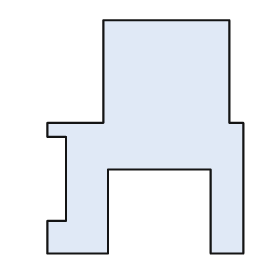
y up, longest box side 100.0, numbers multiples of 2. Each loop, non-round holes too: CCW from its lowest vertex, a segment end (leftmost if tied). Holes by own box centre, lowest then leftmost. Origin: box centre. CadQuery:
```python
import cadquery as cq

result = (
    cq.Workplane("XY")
    .moveTo(-42.0, -50.0)
    .lineTo(-16.0, -50.0)
    .lineTo(-16.0, -14.0)
    .lineTo(28.0, -14.0)
    .lineTo(28.0, -50.0)
    .lineTo(42.0, -50.0)
    .lineTo(42.0, 6.0)
    .lineTo(36.0, 6.0)
    .lineTo(36.0, 50.0)
    .lineTo(-18.0, 50.0)
    .lineTo(-18.0, 6.0)
    .lineTo(-42.0, 6.0)
    .lineTo(-42.0, 0.0)
    .lineTo(-34.0, 0.0)
    .lineTo(-34.0, -36.0)
    .lineTo(-42.0, -36.0)
    .close()
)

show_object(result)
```